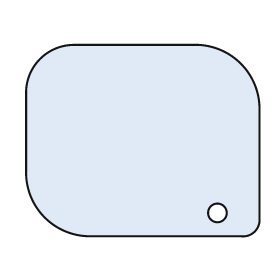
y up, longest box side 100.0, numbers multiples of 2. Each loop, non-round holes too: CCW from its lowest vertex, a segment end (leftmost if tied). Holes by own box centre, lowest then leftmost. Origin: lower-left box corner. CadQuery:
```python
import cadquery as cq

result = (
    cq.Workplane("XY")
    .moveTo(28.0, 0.0)
    .lineTo(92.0, 0.0)
    .threePointArc((98.0, 2.0), (100.0, 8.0))
    .lineTo(100.0, 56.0)
    .threePointArc((92.0, 74.0), (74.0, 82.0))
    .lineTo(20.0, 82.0)
    .threePointArc((6.0, 76.0), (0.0, 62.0))
    .lineTo(0.0, 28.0)
    .threePointArc((8.0, 8.0), (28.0, 0.0))
    .close()
    .moveTo(82.0, 10.0)
    .circle(4.0)
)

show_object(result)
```